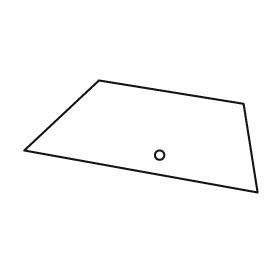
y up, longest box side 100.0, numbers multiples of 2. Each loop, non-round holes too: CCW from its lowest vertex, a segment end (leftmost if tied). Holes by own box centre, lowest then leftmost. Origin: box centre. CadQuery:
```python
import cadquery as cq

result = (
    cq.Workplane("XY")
    .moveTo(50.0, -24.0)
    .lineTo(44.0, 14.0)
    .lineTo(-18.0, 24.0)
    .lineTo(-50.0, -6.0)
    .close()
    .moveTo(8.0, -8.0)
    .circle(2.0)
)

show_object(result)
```